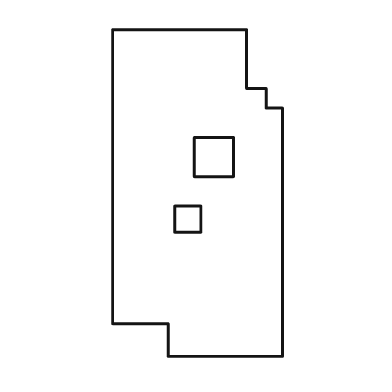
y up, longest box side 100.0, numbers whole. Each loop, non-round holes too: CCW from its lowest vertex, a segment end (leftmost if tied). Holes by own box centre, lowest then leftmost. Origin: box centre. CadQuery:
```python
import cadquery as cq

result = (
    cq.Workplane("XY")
    .moveTo(-9.0, -50.0)
    .lineTo(26.0, -50.0)
    .lineTo(26.0, 26.0)
    .lineTo(21.0, 26.0)
    .lineTo(21.0, 32.0)
    .lineTo(15.0, 32.0)
    .lineTo(15.0, 50.0)
    .lineTo(-26.0, 50.0)
    .lineTo(-26.0, -40.0)
    .lineTo(-9.0, -40.0)
    .close()
    .moveTo(-7.0, -12.0)
    .lineTo(1.0, -12.0)
    .lineTo(1.0, -4.0)
    .lineTo(-7.0, -4.0)
    .close()
    .moveTo(-1.0, 5.0)
    .lineTo(11.0, 5.0)
    .lineTo(11.0, 17.0)
    .lineTo(-1.0, 17.0)
    .close()
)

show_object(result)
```